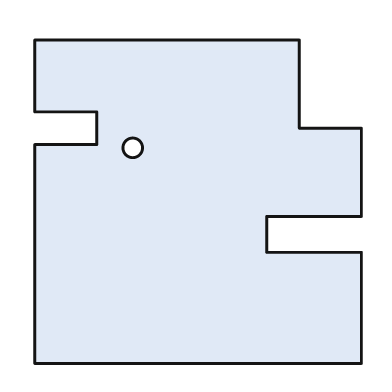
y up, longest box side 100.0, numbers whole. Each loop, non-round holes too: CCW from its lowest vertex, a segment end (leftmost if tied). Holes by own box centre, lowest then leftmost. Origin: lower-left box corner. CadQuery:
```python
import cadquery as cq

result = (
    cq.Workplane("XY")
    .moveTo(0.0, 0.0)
    .lineTo(100.0, 0.0)
    .lineTo(100.0, 34.0)
    .lineTo(71.0, 34.0)
    .lineTo(71.0, 45.0)
    .lineTo(100.0, 45.0)
    .lineTo(100.0, 72.0)
    .lineTo(81.0, 72.0)
    .lineTo(81.0, 99.0)
    .lineTo(0.0, 99.0)
    .lineTo(0.0, 77.0)
    .lineTo(19.0, 77.0)
    .lineTo(19.0, 67.0)
    .lineTo(0.0, 67.0)
    .close()
    .moveTo(30.0, 66.0)
    .circle(3.0)
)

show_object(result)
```